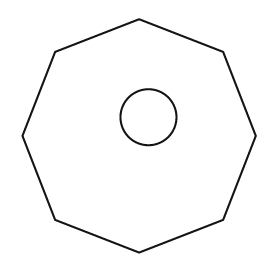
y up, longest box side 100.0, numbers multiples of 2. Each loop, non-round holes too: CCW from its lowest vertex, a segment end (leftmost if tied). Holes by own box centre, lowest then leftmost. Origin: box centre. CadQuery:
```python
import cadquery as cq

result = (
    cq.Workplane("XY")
    .moveTo(0.0, -50.0)
    .lineTo(36.0, -36.0)
    .lineTo(50.0, 0.0)
    .lineTo(36.0, 36.0)
    .lineTo(0.0, 50.0)
    .lineTo(-36.0, 36.0)
    .lineTo(-50.0, 0.0)
    .lineTo(-36.0, -36.0)
    .close()
    .moveTo(4.0, 8.0)
    .circle(12.0)
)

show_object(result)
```